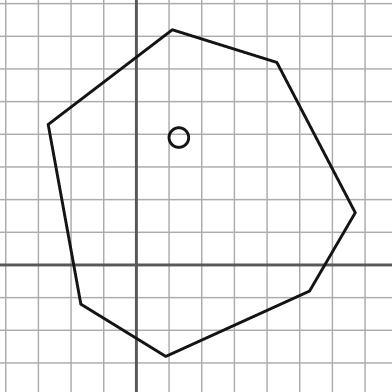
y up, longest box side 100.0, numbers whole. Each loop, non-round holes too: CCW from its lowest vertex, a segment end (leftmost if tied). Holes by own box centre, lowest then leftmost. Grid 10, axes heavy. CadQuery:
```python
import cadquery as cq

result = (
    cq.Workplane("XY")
    .moveTo(9.0, -28.0)
    .lineTo(53.0, -8.0)
    .lineTo(67.0, 16.0)
    .lineTo(43.0, 62.0)
    .lineTo(11.0, 72.0)
    .lineTo(-27.0, 43.0)
    .lineTo(-17.0, -12.0)
    .close()
    .moveTo(13.0, 39.0)
    .circle(3.0)
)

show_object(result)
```